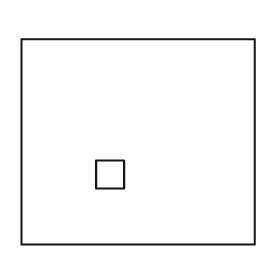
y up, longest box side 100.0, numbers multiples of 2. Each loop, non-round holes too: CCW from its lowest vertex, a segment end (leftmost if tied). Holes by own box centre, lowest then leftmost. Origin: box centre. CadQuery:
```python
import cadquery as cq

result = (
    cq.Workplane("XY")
    .moveTo(-50.0, -44.0)
    .lineTo(50.0, -44.0)
    .lineTo(50.0, 44.0)
    .lineTo(-50.0, 44.0)
    .close()
    .moveTo(-18.0, -20.0)
    .lineTo(-6.0, -20.0)
    .lineTo(-6.0, -8.0)
    .lineTo(-18.0, -8.0)
    .close()
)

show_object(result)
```